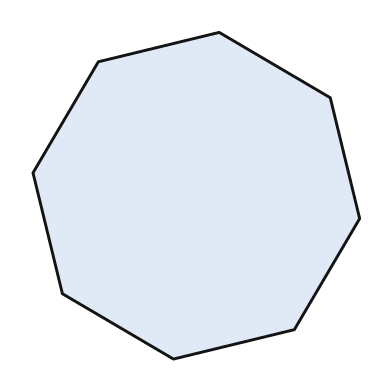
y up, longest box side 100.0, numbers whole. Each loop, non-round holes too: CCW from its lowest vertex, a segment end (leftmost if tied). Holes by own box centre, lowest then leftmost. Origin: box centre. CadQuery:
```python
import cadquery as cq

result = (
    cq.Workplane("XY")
    .moveTo(-7.0, -50.0)
    .lineTo(30.0, -41.0)
    .lineTo(50.0, -7.0)
    .lineTo(41.0, 30.0)
    .lineTo(7.0, 50.0)
    .lineTo(-30.0, 41.0)
    .lineTo(-50.0, 7.0)
    .lineTo(-41.0, -30.0)
    .close()
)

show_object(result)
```